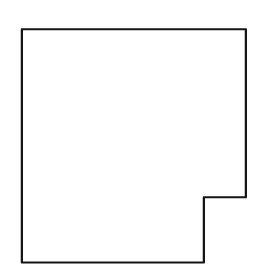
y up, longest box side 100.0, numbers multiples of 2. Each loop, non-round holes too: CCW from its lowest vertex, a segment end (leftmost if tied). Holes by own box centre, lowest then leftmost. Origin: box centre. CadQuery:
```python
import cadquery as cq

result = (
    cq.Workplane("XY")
    .moveTo(-48.0, -50.0)
    .lineTo(30.0, -50.0)
    .lineTo(30.0, -22.0)
    .lineTo(48.0, -22.0)
    .lineTo(48.0, 50.0)
    .lineTo(-48.0, 50.0)
    .close()
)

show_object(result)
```